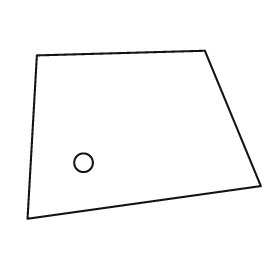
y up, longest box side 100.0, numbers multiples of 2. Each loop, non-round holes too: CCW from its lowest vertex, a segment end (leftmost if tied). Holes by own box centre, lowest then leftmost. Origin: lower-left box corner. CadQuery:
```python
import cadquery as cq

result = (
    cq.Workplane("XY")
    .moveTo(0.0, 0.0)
    .lineTo(100.0, 14.0)
    .lineTo(76.0, 72.0)
    .lineTo(4.0, 70.0)
    .close()
    .moveTo(24.0, 24.0)
    .circle(4.0)
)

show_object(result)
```